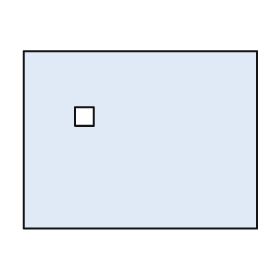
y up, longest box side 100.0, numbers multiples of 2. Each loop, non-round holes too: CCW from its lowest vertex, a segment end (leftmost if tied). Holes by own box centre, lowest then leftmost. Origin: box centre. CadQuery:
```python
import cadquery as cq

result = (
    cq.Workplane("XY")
    .moveTo(-50.0, -38.0)
    .lineTo(50.0, -38.0)
    .lineTo(50.0, 38.0)
    .lineTo(-50.0, 38.0)
    .close()
    .moveTo(-28.0, 6.0)
    .lineTo(-20.0, 6.0)
    .lineTo(-20.0, 14.0)
    .lineTo(-28.0, 14.0)
    .close()
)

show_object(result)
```